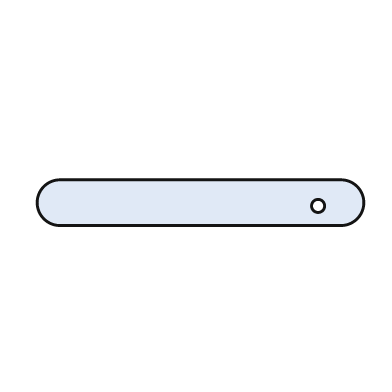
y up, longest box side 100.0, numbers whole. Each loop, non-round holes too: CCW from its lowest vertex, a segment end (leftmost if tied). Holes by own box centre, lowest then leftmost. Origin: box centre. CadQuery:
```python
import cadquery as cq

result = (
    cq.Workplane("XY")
    .moveTo(-43.0, -7.0)
    .lineTo(43.0, -7.0)
    .threePointArc((50.0, 0.0), (43.0, 7.0))
    .lineTo(-43.0, 7.0)
    .threePointArc((-50.0, 0.0), (-43.0, -7.0))
    .close()
    .moveTo(36.0, -1.0)
    .circle(2.0)
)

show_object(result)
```